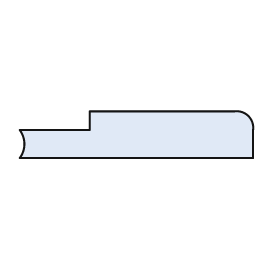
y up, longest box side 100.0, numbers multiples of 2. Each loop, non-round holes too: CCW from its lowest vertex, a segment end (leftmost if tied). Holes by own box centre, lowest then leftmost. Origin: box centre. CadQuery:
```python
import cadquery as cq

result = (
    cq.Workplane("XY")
    .moveTo(-50.0, -10.0)
    .lineTo(50.0, -10.0)
    .lineTo(50.0, 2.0)
    .threePointArc((48.0, 8.0), (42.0, 10.0))
    .lineTo(-20.0, 10.0)
    .lineTo(-20.0, 2.0)
    .lineTo(-50.0, 2.0)
    .threePointArc((-48.0, -4.0), (-50.0, -10.0))
    .close()
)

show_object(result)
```